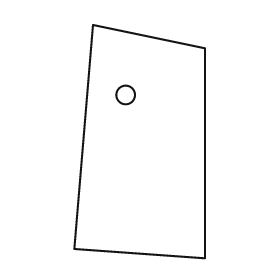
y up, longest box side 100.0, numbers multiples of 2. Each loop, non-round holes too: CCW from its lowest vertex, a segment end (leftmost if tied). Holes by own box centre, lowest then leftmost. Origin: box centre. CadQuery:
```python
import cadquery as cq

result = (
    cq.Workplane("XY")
    .moveTo(28.0, -50.0)
    .lineTo(28.0, 40.0)
    .lineTo(-20.0, 50.0)
    .lineTo(-28.0, -46.0)
    .close()
    .moveTo(-6.0, 20.0)
    .circle(4.0)
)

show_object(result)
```